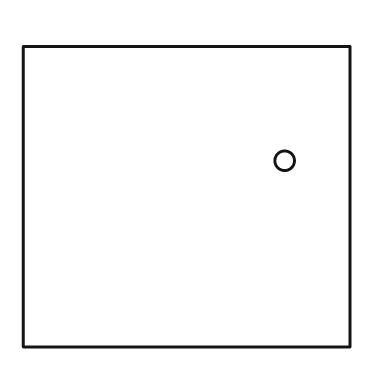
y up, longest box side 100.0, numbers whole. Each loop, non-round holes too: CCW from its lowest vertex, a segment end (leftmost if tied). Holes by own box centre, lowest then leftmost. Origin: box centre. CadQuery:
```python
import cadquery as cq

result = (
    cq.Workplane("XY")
    .moveTo(-50.0, -46.0)
    .lineTo(50.0, -46.0)
    .lineTo(50.0, 46.0)
    .lineTo(-50.0, 46.0)
    .close()
    .moveTo(30.0, 11.0)
    .circle(3.0)
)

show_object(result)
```